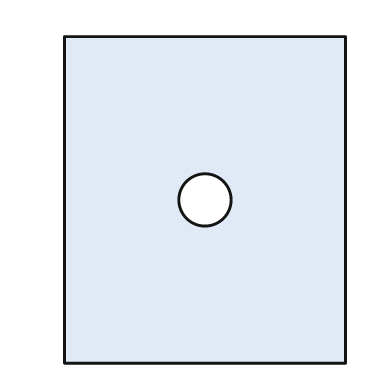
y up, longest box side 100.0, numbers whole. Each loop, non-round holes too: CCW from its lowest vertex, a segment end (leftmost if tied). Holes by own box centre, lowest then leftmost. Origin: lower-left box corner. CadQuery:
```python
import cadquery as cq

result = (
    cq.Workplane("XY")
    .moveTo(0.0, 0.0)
    .lineTo(86.0, 0.0)
    .lineTo(86.0, 100.0)
    .lineTo(0.0, 100.0)
    .close()
    .moveTo(43.0, 50.0)
    .circle(8.0)
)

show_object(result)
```